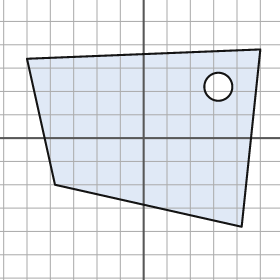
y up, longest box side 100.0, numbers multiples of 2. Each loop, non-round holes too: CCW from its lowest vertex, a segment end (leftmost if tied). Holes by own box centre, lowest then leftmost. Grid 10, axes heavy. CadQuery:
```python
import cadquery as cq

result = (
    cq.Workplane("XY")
    .moveTo(42.0, -38.0)
    .lineTo(50.0, 38.0)
    .lineTo(-50.0, 34.0)
    .lineTo(-38.0, -20.0)
    .close()
    .moveTo(32.0, 22.0)
    .circle(6.0)
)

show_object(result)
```